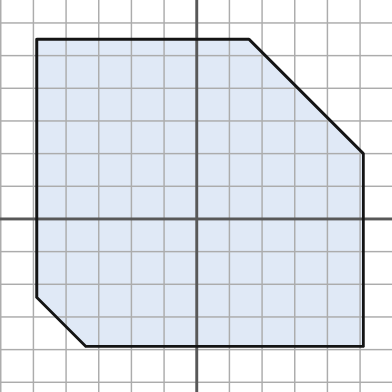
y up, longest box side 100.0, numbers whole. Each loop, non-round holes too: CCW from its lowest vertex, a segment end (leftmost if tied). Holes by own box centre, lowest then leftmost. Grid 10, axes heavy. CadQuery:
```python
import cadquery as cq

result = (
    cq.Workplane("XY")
    .moveTo(-34.0, -39.0)
    .lineTo(51.0, -39.0)
    .lineTo(51.0, 20.0)
    .lineTo(16.0, 55.0)
    .lineTo(-49.0, 55.0)
    .lineTo(-49.0, -24.0)
    .close()
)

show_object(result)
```